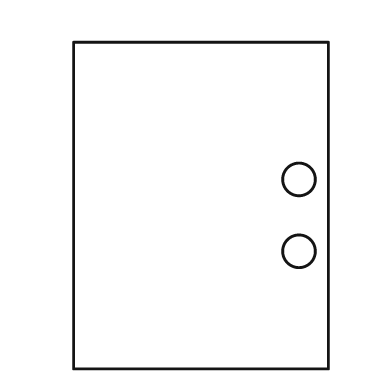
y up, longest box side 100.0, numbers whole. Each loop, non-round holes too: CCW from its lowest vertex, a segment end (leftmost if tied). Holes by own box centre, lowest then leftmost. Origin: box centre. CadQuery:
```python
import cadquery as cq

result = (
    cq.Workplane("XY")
    .moveTo(-39.0, -50.0)
    .lineTo(39.0, -50.0)
    .lineTo(39.0, 50.0)
    .lineTo(-39.0, 50.0)
    .close()
    .moveTo(30.0, -14.0)
    .circle(5.0)
    .moveTo(30.0, 8.0)
    .circle(5.0)
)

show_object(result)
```